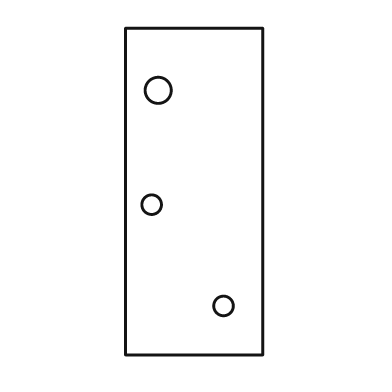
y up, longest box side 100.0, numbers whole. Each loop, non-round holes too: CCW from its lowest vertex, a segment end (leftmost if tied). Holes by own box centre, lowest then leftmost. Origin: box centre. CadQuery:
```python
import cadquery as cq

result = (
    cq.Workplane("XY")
    .moveTo(-21.0, -50.0)
    .lineTo(21.0, -50.0)
    .lineTo(21.0, 50.0)
    .lineTo(-21.0, 50.0)
    .close()
    .moveTo(9.0, -35.0)
    .circle(3.0)
    .moveTo(-13.0, -4.0)
    .circle(3.0)
    .moveTo(-11.0, 31.0)
    .circle(4.0)
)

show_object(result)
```